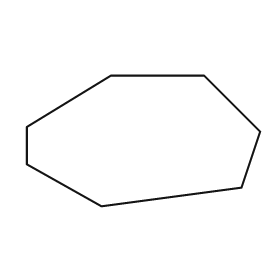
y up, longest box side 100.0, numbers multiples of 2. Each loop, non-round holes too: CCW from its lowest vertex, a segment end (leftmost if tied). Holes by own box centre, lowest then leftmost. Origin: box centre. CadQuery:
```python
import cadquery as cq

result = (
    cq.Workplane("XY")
    .moveTo(-18.0, -28.0)
    .lineTo(42.0, -20.0)
    .lineTo(50.0, 4.0)
    .lineTo(26.0, 28.0)
    .lineTo(-14.0, 28.0)
    .lineTo(-50.0, 6.0)
    .lineTo(-50.0, -10.0)
    .close()
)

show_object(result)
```